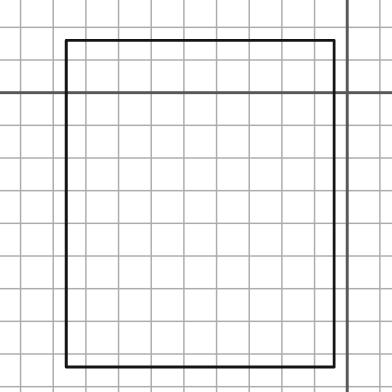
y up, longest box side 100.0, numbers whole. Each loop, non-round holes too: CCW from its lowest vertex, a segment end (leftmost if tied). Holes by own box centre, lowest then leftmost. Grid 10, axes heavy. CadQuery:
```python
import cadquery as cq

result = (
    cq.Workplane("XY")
    .moveTo(-86.0, -84.0)
    .lineTo(-4.0, -84.0)
    .lineTo(-4.0, 16.0)
    .lineTo(-86.0, 16.0)
    .close()
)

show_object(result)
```